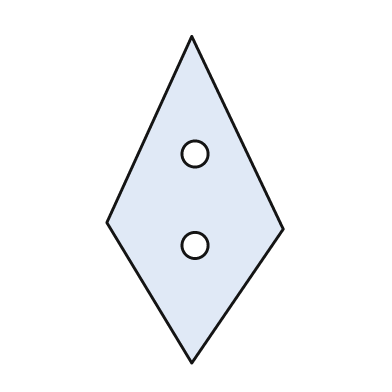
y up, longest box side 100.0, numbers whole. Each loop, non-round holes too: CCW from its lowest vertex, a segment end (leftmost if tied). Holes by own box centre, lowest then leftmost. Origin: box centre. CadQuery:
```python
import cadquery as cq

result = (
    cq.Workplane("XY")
    .moveTo(-1.0, -50.0)
    .lineTo(27.0, -9.0)
    .lineTo(-1.0, 50.0)
    .lineTo(-27.0, -7.0)
    .close()
    .moveTo(0.0, -14.0)
    .circle(4.0)
    .moveTo(0.0, 14.0)
    .circle(4.0)
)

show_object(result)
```